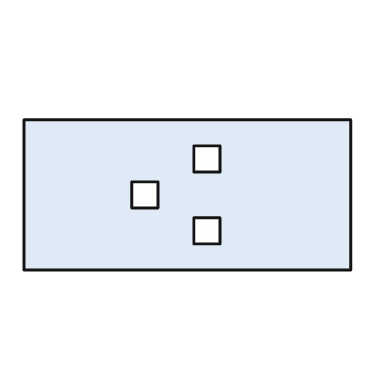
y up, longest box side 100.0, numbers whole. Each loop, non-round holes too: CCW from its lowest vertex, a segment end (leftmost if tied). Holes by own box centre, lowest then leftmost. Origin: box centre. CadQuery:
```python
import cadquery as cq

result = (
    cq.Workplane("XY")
    .moveTo(-50.0, -23.0)
    .lineTo(50.0, -23.0)
    .lineTo(50.0, 23.0)
    .lineTo(-50.0, 23.0)
    .close()
    .moveTo(2.0, -15.0)
    .lineTo(10.0, -15.0)
    .lineTo(10.0, -7.0)
    .lineTo(2.0, -7.0)
    .close()
    .moveTo(-17.0, -4.0)
    .lineTo(-9.0, -4.0)
    .lineTo(-9.0, 4.0)
    .lineTo(-17.0, 4.0)
    .close()
    .moveTo(2.0, 7.0)
    .lineTo(10.0, 7.0)
    .lineTo(10.0, 15.0)
    .lineTo(2.0, 15.0)
    .close()
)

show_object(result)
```